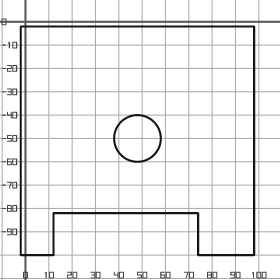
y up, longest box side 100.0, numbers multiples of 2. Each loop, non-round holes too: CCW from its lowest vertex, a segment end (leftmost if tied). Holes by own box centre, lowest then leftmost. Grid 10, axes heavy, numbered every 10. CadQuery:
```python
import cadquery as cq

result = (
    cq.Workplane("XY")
    .moveTo(-2.0, -100.0)
    .lineTo(12.0, -100.0)
    .lineTo(12.0, -82.0)
    .lineTo(74.0, -82.0)
    .lineTo(74.0, -100.0)
    .lineTo(98.0, -100.0)
    .lineTo(98.0, -2.0)
    .lineTo(-2.0, -2.0)
    .close()
    .moveTo(48.0, -50.0)
    .circle(10.0)
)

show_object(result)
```